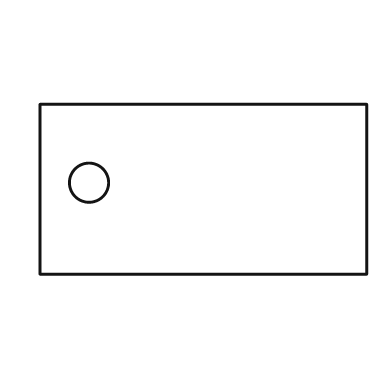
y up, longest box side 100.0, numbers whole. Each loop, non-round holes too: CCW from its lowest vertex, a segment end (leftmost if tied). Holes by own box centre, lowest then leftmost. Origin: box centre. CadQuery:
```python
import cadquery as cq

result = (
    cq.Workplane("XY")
    .moveTo(-50.0, -26.0)
    .lineTo(50.0, -26.0)
    .lineTo(50.0, 26.0)
    .lineTo(-50.0, 26.0)
    .close()
    .moveTo(-35.0, 2.0)
    .circle(6.0)
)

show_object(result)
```